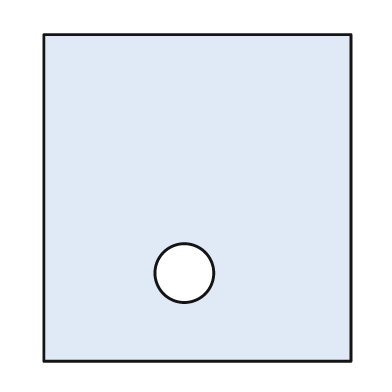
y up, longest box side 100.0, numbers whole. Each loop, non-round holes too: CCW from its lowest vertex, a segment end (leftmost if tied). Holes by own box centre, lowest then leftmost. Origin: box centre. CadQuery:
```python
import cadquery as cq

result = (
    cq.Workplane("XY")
    .moveTo(-47.0, -50.0)
    .lineTo(47.0, -50.0)
    .lineTo(47.0, 50.0)
    .lineTo(-47.0, 50.0)
    .close()
    .moveTo(-4.0, -23.0)
    .circle(9.0)
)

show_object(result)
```